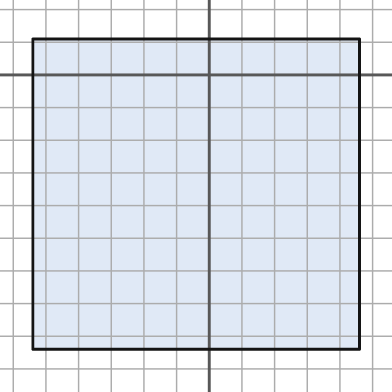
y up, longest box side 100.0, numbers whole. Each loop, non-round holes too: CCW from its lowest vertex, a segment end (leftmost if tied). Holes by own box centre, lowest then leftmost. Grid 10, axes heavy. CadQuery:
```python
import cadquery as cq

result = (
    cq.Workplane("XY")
    .moveTo(-54.0, -84.0)
    .lineTo(46.0, -84.0)
    .lineTo(46.0, 11.0)
    .lineTo(-54.0, 11.0)
    .close()
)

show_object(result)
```